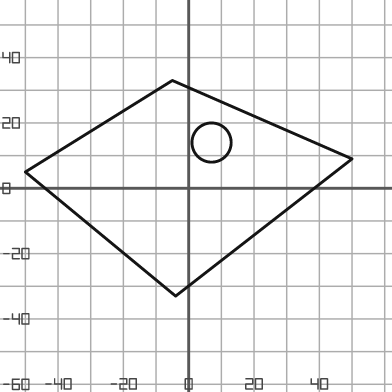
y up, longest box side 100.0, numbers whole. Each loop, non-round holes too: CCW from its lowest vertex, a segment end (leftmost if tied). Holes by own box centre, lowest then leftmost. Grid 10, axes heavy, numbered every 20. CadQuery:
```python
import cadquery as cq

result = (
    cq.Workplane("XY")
    .moveTo(-4.0, -33.0)
    .lineTo(50.0, 9.0)
    .lineTo(-5.0, 33.0)
    .lineTo(-50.0, 5.0)
    .close()
    .moveTo(7.0, 14.0)
    .circle(6.0)
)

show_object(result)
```